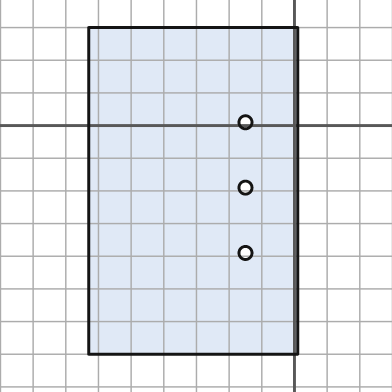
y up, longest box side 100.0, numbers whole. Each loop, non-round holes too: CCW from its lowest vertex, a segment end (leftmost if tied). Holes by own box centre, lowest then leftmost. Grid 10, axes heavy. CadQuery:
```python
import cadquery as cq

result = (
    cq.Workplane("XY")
    .moveTo(-63.0, -70.0)
    .lineTo(1.0, -70.0)
    .lineTo(1.0, 30.0)
    .lineTo(-63.0, 30.0)
    .close()
    .moveTo(-15.0, -39.0)
    .circle(2.0)
    .moveTo(-15.0, -19.0)
    .circle(2.0)
    .moveTo(-15.0, 1.0)
    .circle(2.0)
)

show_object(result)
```